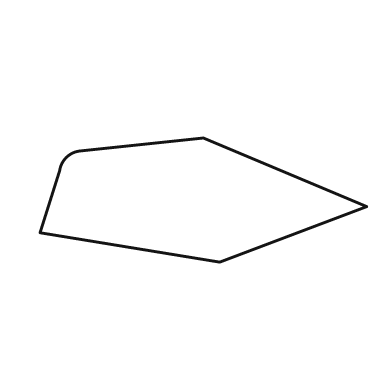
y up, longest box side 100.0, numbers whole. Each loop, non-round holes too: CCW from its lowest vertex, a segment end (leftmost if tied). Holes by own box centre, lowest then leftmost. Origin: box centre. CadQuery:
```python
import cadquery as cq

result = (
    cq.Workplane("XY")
    .moveTo(5.0, -19.0)
    .lineTo(50.0, -2.0)
    .lineTo(0.0, 19.0)
    .lineTo(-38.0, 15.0)
    .threePointArc((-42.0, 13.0), (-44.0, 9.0))
    .lineTo(-50.0, -10.0)
    .close()
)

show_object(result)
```